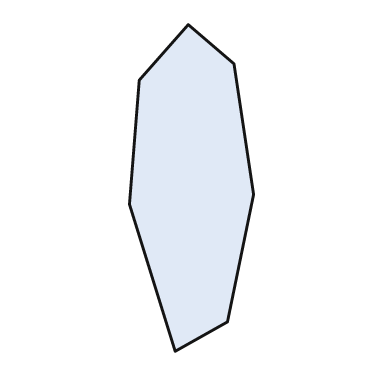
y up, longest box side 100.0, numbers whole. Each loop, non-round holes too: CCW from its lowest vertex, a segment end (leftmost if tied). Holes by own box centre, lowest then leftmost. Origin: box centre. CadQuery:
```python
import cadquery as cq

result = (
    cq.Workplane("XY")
    .moveTo(-5.0, -50.0)
    .lineTo(11.0, -41.0)
    .lineTo(19.0, -2.0)
    .lineTo(13.0, 38.0)
    .lineTo(-1.0, 50.0)
    .lineTo(-16.0, 33.0)
    .lineTo(-19.0, -5.0)
    .close()
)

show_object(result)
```